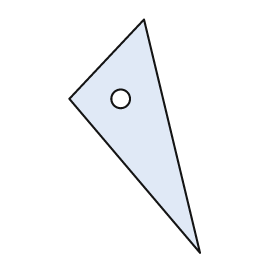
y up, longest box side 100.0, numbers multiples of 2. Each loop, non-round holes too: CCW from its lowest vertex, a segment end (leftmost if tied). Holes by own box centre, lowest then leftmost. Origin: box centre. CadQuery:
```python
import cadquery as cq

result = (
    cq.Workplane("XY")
    .moveTo(28.0, -50.0)
    .lineTo(4.0, 50.0)
    .lineTo(-28.0, 16.0)
    .close()
    .moveTo(-6.0, 16.0)
    .circle(4.0)
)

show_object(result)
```